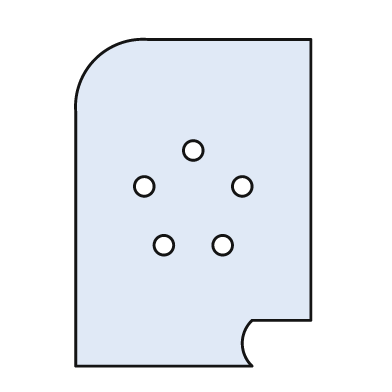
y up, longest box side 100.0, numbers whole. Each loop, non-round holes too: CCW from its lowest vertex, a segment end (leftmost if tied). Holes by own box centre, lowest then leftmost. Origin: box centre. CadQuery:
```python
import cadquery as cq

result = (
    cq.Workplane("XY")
    .moveTo(-36.0, -50.0)
    .lineTo(18.0, -50.0)
    .threePointArc((15.0, -43.0), (18.0, -36.0))
    .lineTo(36.0, -36.0)
    .lineTo(36.0, 50.0)
    .lineTo(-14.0, 50.0)
    .threePointArc((-30.0, 44.0), (-36.0, 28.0))
    .close()
    .moveTo(-9.0, -13.0)
    .circle(3.0)
    .moveTo(9.0, -13.0)
    .circle(3.0)
    .moveTo(-15.0, 5.0)
    .circle(3.0)
    .moveTo(15.0, 5.0)
    .circle(3.0)
    .moveTo(0.0, 16.0)
    .circle(3.0)
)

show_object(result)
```